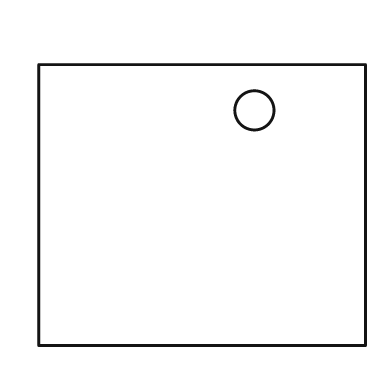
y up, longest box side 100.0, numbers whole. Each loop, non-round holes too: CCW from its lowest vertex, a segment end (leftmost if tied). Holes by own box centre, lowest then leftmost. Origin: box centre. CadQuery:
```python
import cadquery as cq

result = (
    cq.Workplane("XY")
    .moveTo(-50.0, -43.0)
    .lineTo(50.0, -43.0)
    .lineTo(50.0, 43.0)
    .lineTo(-50.0, 43.0)
    .close()
    .moveTo(16.0, 29.0)
    .circle(6.0)
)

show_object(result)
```